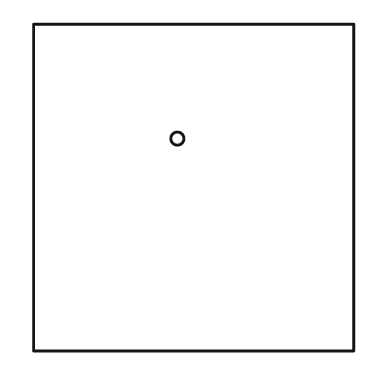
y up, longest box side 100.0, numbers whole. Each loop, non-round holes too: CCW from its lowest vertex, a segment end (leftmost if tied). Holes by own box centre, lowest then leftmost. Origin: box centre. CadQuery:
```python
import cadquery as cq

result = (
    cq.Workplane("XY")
    .moveTo(-49.0, -50.0)
    .lineTo(49.0, -50.0)
    .lineTo(49.0, 50.0)
    .lineTo(-49.0, 50.0)
    .close()
    .moveTo(-5.0, 15.0)
    .circle(2.0)
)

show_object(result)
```